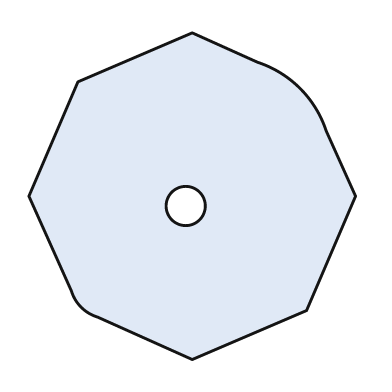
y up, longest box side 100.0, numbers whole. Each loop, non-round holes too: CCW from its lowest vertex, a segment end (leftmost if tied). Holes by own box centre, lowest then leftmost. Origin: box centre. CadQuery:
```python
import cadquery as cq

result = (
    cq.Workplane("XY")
    .moveTo(0.0, -50.0)
    .lineTo(35.0, -35.0)
    .lineTo(50.0, 0.0)
    .lineTo(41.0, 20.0)
    .threePointArc((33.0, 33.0), (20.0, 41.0))
    .lineTo(0.0, 50.0)
    .lineTo(-35.0, 35.0)
    .lineTo(-50.0, 0.0)
    .lineTo(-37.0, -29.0)
    .threePointArc((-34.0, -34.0), (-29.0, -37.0))
    .close()
    .moveTo(-2.0, -3.0)
    .circle(6.0)
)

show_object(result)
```